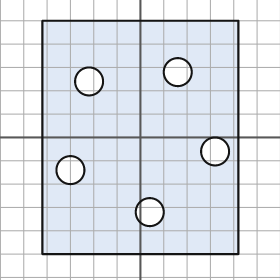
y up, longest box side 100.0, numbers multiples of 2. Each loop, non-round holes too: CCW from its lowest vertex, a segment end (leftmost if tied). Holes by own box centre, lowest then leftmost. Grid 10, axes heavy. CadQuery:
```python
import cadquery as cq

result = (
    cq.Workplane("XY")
    .moveTo(-42.0, -50.0)
    .lineTo(42.0, -50.0)
    .lineTo(42.0, 50.0)
    .lineTo(-42.0, 50.0)
    .close()
    .moveTo(4.0, -32.0)
    .circle(6.0)
    .moveTo(-30.0, -14.0)
    .circle(6.0)
    .moveTo(32.0, -6.0)
    .circle(6.0)
    .moveTo(-22.0, 24.0)
    .circle(6.0)
    .moveTo(16.0, 28.0)
    .circle(6.0)
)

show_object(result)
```